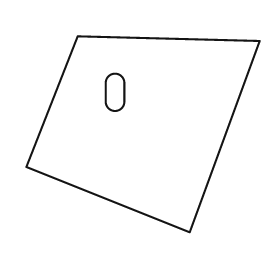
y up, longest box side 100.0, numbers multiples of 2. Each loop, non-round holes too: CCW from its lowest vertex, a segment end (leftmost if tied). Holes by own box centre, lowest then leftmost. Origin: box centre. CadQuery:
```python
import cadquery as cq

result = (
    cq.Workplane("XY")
    .moveTo(20.0, -42.0)
    .lineTo(50.0, 40.0)
    .lineTo(-28.0, 42.0)
    .lineTo(-50.0, -14.0)
    .close()
    .moveTo(-16.0, 14.0)
    .threePointArc((-12.0, 10.0), (-8.0, 14.0))
    .lineTo(-8.0, 22.0)
    .threePointArc((-12.0, 26.0), (-16.0, 22.0))
    .close()
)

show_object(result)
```